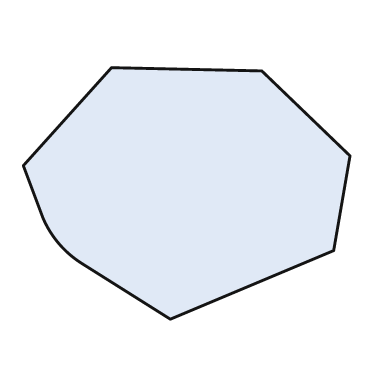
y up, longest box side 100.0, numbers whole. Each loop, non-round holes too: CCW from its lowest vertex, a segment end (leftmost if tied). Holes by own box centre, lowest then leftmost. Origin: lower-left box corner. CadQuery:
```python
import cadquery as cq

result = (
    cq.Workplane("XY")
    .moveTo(45.0, 0.0)
    .lineTo(95.0, 21.0)
    .lineTo(100.0, 50.0)
    .lineTo(73.0, 76.0)
    .lineTo(27.0, 77.0)
    .lineTo(0.0, 47.0)
    .lineTo(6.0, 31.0)
    .threePointArc((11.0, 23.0), (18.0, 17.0))
    .close()
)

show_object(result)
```